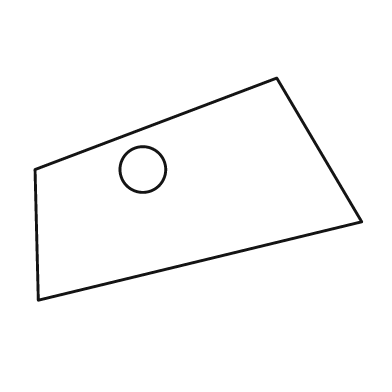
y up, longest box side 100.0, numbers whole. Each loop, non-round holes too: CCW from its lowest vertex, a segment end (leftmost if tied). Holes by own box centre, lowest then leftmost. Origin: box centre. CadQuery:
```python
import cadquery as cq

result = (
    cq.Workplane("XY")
    .moveTo(-49.0, -34.0)
    .lineTo(50.0, -10.0)
    .lineTo(24.0, 34.0)
    .lineTo(-50.0, 6.0)
    .close()
    .moveTo(-17.0, 6.0)
    .circle(7.0)
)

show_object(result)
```